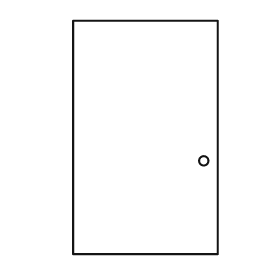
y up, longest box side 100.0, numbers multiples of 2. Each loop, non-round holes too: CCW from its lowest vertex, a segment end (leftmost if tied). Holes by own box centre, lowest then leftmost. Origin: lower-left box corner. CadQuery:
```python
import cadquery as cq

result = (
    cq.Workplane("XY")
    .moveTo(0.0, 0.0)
    .lineTo(62.0, 0.0)
    .lineTo(62.0, 100.0)
    .lineTo(0.0, 100.0)
    .close()
    .moveTo(56.0, 40.0)
    .circle(2.0)
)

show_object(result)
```